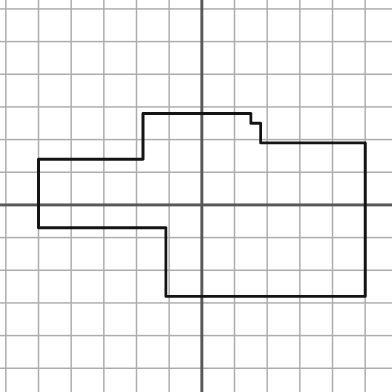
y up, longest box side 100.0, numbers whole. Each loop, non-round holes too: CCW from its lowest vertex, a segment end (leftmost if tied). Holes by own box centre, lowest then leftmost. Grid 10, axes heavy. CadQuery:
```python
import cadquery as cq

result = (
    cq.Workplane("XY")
    .moveTo(-11.0, -28.0)
    .lineTo(50.0, -28.0)
    .lineTo(50.0, 19.0)
    .lineTo(18.0, 19.0)
    .lineTo(18.0, 25.0)
    .lineTo(15.0, 25.0)
    .lineTo(15.0, 28.0)
    .lineTo(-18.0, 28.0)
    .lineTo(-18.0, 14.0)
    .lineTo(-50.0, 14.0)
    .lineTo(-50.0, -7.0)
    .lineTo(-11.0, -7.0)
    .close()
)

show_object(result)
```